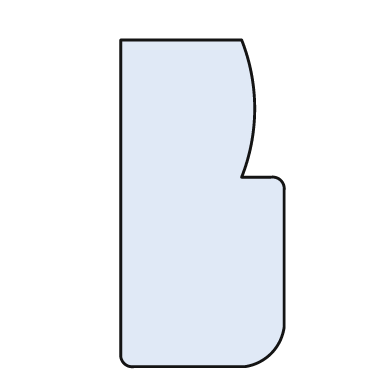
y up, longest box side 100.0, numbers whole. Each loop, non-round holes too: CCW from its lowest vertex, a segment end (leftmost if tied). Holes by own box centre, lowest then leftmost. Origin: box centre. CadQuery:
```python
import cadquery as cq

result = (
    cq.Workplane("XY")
    .moveTo(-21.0, -50.0)
    .lineTo(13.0, -50.0)
    .threePointArc((21.0, -46.0), (25.0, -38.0))
    .lineTo(25.0, 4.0)
    .threePointArc((24.0, 7.0), (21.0, 8.0))
    .lineTo(12.0, 8.0)
    .threePointArc((16.0, 29.0), (12.0, 50.0))
    .lineTo(-25.0, 50.0)
    .lineTo(-25.0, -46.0)
    .threePointArc((-24.0, -49.0), (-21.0, -50.0))
    .close()
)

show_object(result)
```